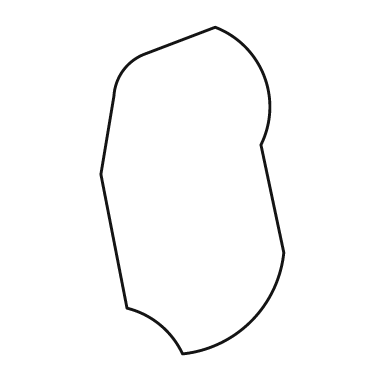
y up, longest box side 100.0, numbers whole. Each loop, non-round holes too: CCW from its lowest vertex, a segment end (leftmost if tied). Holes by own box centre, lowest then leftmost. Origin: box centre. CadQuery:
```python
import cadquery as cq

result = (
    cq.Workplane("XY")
    .moveTo(-3.0, -50.0)
    .threePointArc((18.0, -40.0), (28.0, -19.0))
    .lineTo(21.0, 14.0)
    .threePointArc((22.0, 35.0), (7.0, 50.0))
    .lineTo(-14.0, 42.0)
    .threePointArc((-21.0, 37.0), (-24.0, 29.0))
    .lineTo(-28.0, 5.0)
    .lineTo(-20.0, -36.0)
    .threePointArc((-10.0, -41.0), (-3.0, -50.0))
    .close()
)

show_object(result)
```